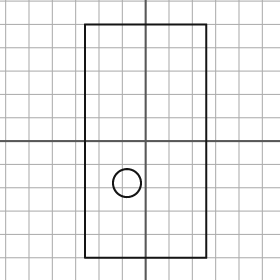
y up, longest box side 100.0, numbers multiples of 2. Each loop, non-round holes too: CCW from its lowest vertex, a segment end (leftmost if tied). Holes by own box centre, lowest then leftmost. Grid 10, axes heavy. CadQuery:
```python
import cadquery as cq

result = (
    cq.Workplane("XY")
    .moveTo(-26.0, -50.0)
    .lineTo(26.0, -50.0)
    .lineTo(26.0, 50.0)
    .lineTo(-26.0, 50.0)
    .close()
    .moveTo(-8.0, -18.0)
    .circle(6.0)
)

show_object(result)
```